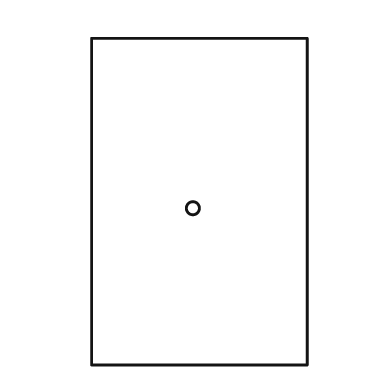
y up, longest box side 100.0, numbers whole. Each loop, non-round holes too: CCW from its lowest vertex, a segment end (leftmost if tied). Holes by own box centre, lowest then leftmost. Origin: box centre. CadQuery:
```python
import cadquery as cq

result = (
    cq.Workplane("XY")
    .moveTo(-33.0, -50.0)
    .lineTo(33.0, -50.0)
    .lineTo(33.0, 50.0)
    .lineTo(-33.0, 50.0)
    .close()
    .moveTo(-2.0, -2.0)
    .circle(2.0)
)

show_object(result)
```